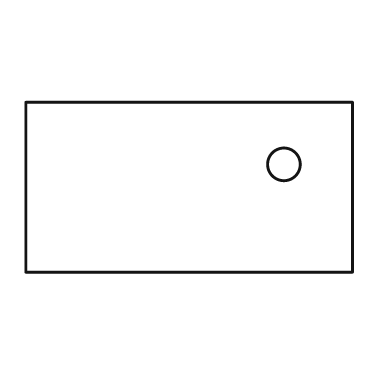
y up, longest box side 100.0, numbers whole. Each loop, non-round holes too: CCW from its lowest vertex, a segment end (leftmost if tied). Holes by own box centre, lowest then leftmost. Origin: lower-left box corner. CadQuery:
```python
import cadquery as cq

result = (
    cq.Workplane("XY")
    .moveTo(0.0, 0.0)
    .lineTo(100.0, 0.0)
    .lineTo(100.0, 52.0)
    .lineTo(0.0, 52.0)
    .close()
    .moveTo(79.0, 33.0)
    .circle(5.0)
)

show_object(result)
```